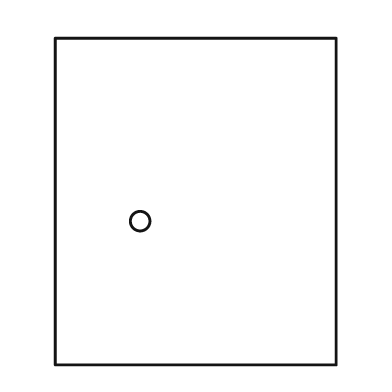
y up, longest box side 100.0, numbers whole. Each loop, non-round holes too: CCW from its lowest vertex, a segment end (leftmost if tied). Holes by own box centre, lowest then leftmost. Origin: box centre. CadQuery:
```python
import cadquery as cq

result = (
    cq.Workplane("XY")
    .moveTo(-43.0, -50.0)
    .lineTo(43.0, -50.0)
    .lineTo(43.0, 50.0)
    .lineTo(-43.0, 50.0)
    .close()
    .moveTo(-17.0, -6.0)
    .circle(3.0)
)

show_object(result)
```